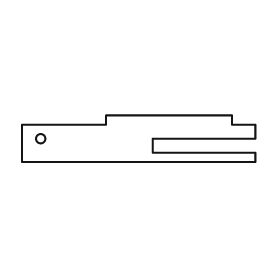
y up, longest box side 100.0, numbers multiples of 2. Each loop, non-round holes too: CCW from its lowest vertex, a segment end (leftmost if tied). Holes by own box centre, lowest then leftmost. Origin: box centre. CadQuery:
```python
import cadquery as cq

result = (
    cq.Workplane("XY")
    .moveTo(-50.0, -10.0)
    .lineTo(50.0, -10.0)
    .lineTo(50.0, -6.0)
    .lineTo(6.0, -6.0)
    .lineTo(6.0, 0.0)
    .lineTo(50.0, 0.0)
    .lineTo(50.0, 6.0)
    .lineTo(40.0, 6.0)
    .lineTo(40.0, 10.0)
    .lineTo(-14.0, 10.0)
    .lineTo(-14.0, 6.0)
    .lineTo(-50.0, 6.0)
    .close()
    .moveTo(-42.0, 0.0)
    .circle(2.0)
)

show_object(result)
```